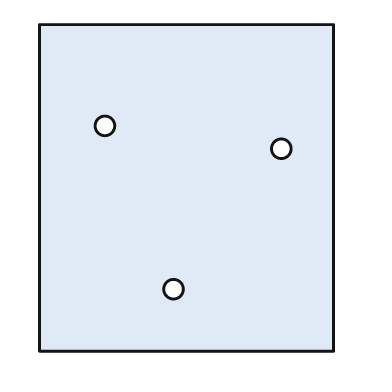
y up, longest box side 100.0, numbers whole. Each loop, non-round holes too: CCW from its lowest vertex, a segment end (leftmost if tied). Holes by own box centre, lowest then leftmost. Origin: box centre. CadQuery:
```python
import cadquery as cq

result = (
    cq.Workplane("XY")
    .moveTo(-45.0, -50.0)
    .lineTo(45.0, -50.0)
    .lineTo(45.0, 50.0)
    .lineTo(-45.0, 50.0)
    .close()
    .moveTo(-4.0, -31.0)
    .circle(3.0)
    .moveTo(29.0, 12.0)
    .circle(3.0)
    .moveTo(-25.0, 19.0)
    .circle(3.0)
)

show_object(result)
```